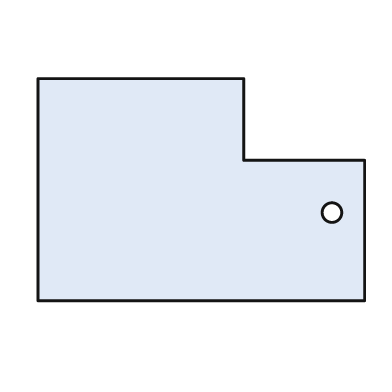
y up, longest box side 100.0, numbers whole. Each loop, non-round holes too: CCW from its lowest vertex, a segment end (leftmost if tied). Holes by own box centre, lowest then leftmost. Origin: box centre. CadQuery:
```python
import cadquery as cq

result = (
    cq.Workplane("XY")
    .moveTo(-50.0, -34.0)
    .lineTo(50.0, -34.0)
    .lineTo(50.0, 9.0)
    .lineTo(13.0, 9.0)
    .lineTo(13.0, 34.0)
    .lineTo(-50.0, 34.0)
    .close()
    .moveTo(40.0, -7.0)
    .circle(3.0)
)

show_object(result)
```